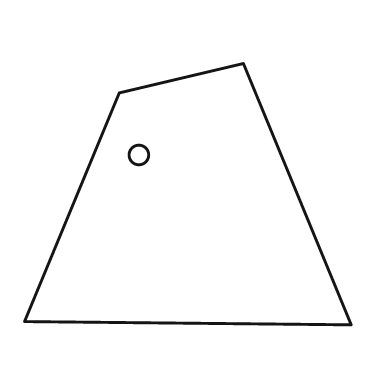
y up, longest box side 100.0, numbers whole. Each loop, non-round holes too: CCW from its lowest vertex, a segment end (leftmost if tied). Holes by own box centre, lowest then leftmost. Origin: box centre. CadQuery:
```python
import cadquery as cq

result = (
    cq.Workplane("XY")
    .moveTo(50.0, -40.0)
    .lineTo(17.0, 40.0)
    .lineTo(-21.0, 31.0)
    .lineTo(-50.0, -39.0)
    .close()
    .moveTo(-15.0, 12.0)
    .circle(3.0)
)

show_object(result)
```